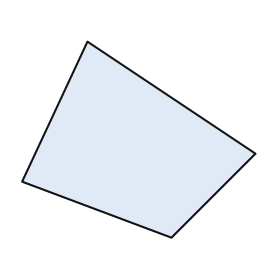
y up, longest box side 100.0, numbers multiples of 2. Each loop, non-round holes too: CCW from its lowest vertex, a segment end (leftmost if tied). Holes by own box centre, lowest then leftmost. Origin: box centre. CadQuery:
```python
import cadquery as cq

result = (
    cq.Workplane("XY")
    .moveTo(14.0, -42.0)
    .lineTo(50.0, -6.0)
    .lineTo(-22.0, 42.0)
    .lineTo(-50.0, -18.0)
    .close()
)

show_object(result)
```